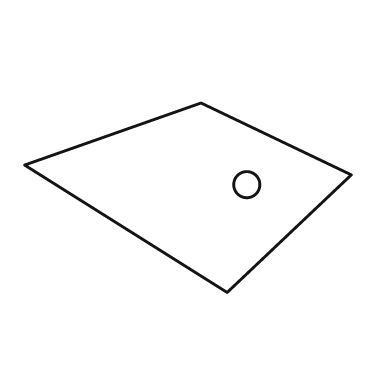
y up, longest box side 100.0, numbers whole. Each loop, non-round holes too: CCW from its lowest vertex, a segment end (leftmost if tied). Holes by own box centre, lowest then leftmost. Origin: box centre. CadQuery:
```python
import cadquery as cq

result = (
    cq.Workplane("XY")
    .moveTo(12.0, -29.0)
    .lineTo(50.0, 7.0)
    .lineTo(4.0, 29.0)
    .lineTo(-50.0, 10.0)
    .close()
    .moveTo(18.0, 4.0)
    .circle(4.0)
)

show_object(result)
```